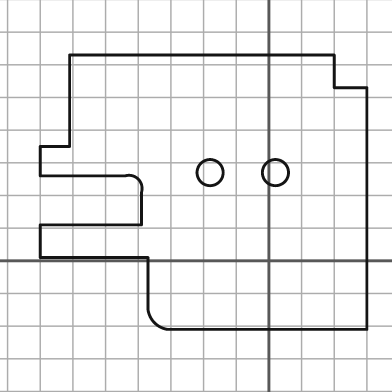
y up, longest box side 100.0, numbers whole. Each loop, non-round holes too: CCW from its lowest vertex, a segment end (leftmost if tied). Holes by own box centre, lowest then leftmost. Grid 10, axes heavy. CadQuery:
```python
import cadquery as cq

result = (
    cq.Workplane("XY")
    .moveTo(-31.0, -21.0)
    .lineTo(30.0, -21.0)
    .lineTo(30.0, 53.0)
    .lineTo(20.0, 53.0)
    .lineTo(20.0, 63.0)
    .lineTo(-61.0, 63.0)
    .lineTo(-61.0, 35.0)
    .lineTo(-70.0, 35.0)
    .lineTo(-70.0, 26.0)
    .lineTo(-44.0, 26.0)
    .threePointArc((-40.0, 25.0), (-39.0, 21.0))
    .lineTo(-39.0, 11.0)
    .lineTo(-70.0, 11.0)
    .lineTo(-70.0, 1.0)
    .lineTo(-37.0, 1.0)
    .lineTo(-37.0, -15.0)
    .threePointArc((-35.0, -19.0), (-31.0, -21.0))
    .close()
    .moveTo(-18.0, 27.0)
    .circle(4.0)
    .moveTo(2.0, 27.0)
    .circle(4.0)
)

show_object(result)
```